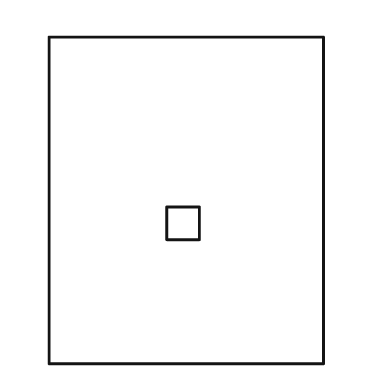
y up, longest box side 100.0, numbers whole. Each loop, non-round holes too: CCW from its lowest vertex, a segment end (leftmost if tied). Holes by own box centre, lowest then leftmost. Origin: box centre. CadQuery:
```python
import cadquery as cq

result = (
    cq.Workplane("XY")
    .moveTo(-42.0, -50.0)
    .lineTo(42.0, -50.0)
    .lineTo(42.0, 50.0)
    .lineTo(-42.0, 50.0)
    .close()
    .moveTo(-6.0, -12.0)
    .lineTo(4.0, -12.0)
    .lineTo(4.0, -2.0)
    .lineTo(-6.0, -2.0)
    .close()
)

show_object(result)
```